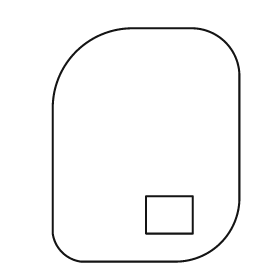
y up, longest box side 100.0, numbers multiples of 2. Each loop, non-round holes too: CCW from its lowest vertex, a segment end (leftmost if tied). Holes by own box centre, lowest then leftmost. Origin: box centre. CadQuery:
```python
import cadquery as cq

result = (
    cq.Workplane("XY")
    .moveTo(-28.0, -50.0)
    .lineTo(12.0, -50.0)
    .threePointArc((32.0, -42.0), (40.0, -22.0))
    .lineTo(40.0, 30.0)
    .threePointArc((34.0, 44.0), (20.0, 50.0))
    .lineTo(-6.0, 50.0)
    .threePointArc((-30.0, 40.0), (-40.0, 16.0))
    .lineTo(-40.0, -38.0)
    .threePointArc((-36.0, -46.0), (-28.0, -50.0))
    .close()
    .moveTo(0.0, -38.0)
    .lineTo(20.0, -38.0)
    .lineTo(20.0, -22.0)
    .lineTo(0.0, -22.0)
    .close()
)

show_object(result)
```